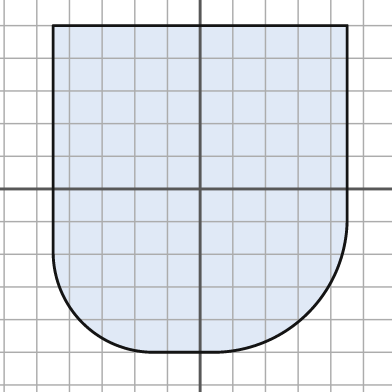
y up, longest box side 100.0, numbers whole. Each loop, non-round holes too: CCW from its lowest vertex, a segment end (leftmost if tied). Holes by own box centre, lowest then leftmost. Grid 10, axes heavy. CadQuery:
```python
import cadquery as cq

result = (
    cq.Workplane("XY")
    .moveTo(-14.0, -50.0)
    .lineTo(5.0, -50.0)
    .threePointArc((33.0, -38.0), (45.0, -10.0))
    .lineTo(45.0, 50.0)
    .lineTo(-45.0, 50.0)
    .lineTo(-45.0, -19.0)
    .threePointArc((-36.0, -41.0), (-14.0, -50.0))
    .close()
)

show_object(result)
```